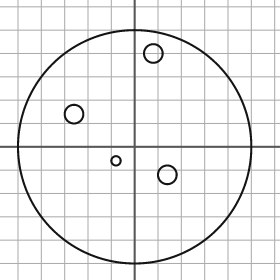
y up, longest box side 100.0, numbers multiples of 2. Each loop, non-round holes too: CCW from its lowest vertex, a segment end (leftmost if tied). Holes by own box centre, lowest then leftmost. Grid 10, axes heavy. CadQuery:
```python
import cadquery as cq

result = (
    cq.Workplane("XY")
    .moveTo(0.0, 0.0)
    .circle(50.0)
    .moveTo(14.0, -12.0)
    .circle(4.0)
    .moveTo(-8.0, -6.0)
    .circle(2.0)
    .moveTo(-26.0, 14.0)
    .circle(4.0)
    .moveTo(8.0, 40.0)
    .circle(4.0)
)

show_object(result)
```